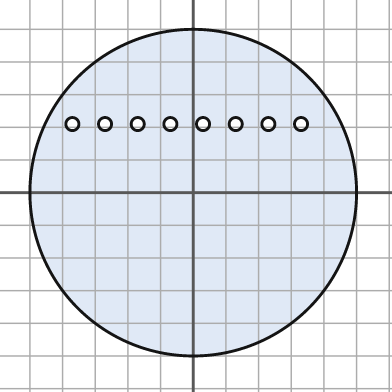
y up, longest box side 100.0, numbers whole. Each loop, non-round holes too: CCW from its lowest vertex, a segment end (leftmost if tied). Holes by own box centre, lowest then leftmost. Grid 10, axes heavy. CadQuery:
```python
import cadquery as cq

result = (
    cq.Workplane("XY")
    .moveTo(0.0, 0.0)
    .circle(50.0)
    .moveTo(-37.0, 21.0)
    .circle(2.0)
    .moveTo(-27.0, 21.0)
    .circle(2.0)
    .moveTo(-17.0, 21.0)
    .circle(2.0)
    .moveTo(-7.0, 21.0)
    .circle(2.0)
    .moveTo(3.0, 21.0)
    .circle(2.0)
    .moveTo(13.0, 21.0)
    .circle(2.0)
    .moveTo(23.0, 21.0)
    .circle(2.0)
    .moveTo(33.0, 21.0)
    .circle(2.0)
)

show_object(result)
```